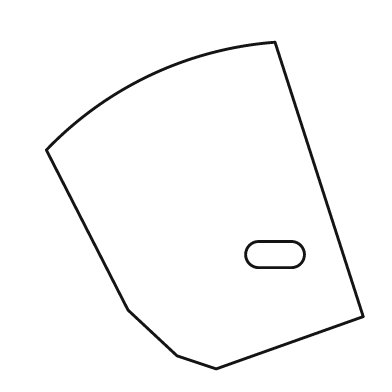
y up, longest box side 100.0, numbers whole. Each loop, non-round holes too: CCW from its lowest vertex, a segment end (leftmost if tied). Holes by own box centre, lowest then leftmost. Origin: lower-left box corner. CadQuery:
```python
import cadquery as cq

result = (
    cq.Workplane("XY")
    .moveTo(52.0, 0.0)
    .lineTo(97.0, 16.0)
    .lineTo(70.0, 100.0)
    .threePointArc((32.0, 90.0), (0.0, 67.0))
    .lineTo(25.0, 18.0)
    .lineTo(40.0, 4.0)
    .close()
    .moveTo(65.0, 31.0)
    .lineTo(75.0, 31.0)
    .threePointArc((79.0, 35.0), (75.0, 39.0))
    .lineTo(65.0, 39.0)
    .threePointArc((61.0, 35.0), (65.0, 31.0))
    .close()
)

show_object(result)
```